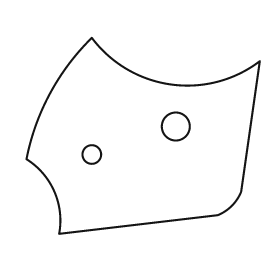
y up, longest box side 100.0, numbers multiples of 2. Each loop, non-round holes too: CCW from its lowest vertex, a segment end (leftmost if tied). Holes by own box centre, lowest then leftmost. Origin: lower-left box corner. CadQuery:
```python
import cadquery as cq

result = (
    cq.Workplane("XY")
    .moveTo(14.0, 0.0)
    .lineTo(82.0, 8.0)
    .threePointArc((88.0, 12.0), (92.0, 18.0))
    .lineTo(100.0, 74.0)
    .threePointArc((62.0, 64.0), (28.0, 84.0))
    .threePointArc((10.0, 60.0), (0.0, 32.0))
    .threePointArc((12.0, 18.0), (14.0, 0.0))
    .close()
    .moveTo(28.0, 34.0)
    .circle(4.0)
    .moveTo(64.0, 46.0)
    .circle(6.0)
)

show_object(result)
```